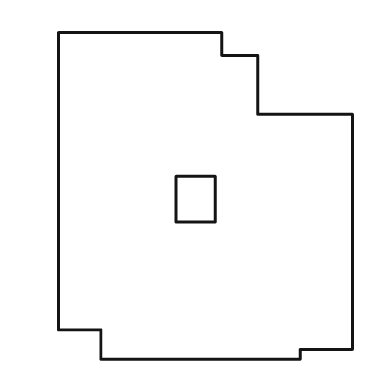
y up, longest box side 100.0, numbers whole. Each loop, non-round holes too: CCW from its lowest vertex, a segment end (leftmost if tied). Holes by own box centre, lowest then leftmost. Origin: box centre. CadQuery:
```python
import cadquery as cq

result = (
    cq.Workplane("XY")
    .moveTo(-32.0, -50.0)
    .lineTo(29.0, -50.0)
    .lineTo(29.0, -47.0)
    .lineTo(45.0, -47.0)
    .lineTo(45.0, 25.0)
    .lineTo(16.0, 25.0)
    .lineTo(16.0, 43.0)
    .lineTo(5.0, 43.0)
    .lineTo(5.0, 50.0)
    .lineTo(-45.0, 50.0)
    .lineTo(-45.0, -41.0)
    .lineTo(-32.0, -41.0)
    .close()
    .moveTo(-9.0, -8.0)
    .lineTo(3.0, -8.0)
    .lineTo(3.0, 6.0)
    .lineTo(-9.0, 6.0)
    .close()
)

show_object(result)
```